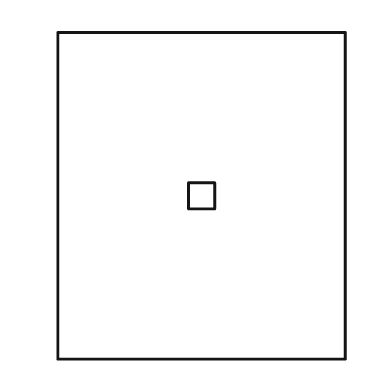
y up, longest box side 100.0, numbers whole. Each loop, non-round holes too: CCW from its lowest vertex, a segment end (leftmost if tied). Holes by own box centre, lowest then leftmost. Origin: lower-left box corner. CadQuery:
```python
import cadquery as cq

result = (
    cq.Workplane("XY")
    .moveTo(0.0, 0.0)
    .lineTo(88.0, 0.0)
    .lineTo(88.0, 100.0)
    .lineTo(0.0, 100.0)
    .close()
    .moveTo(40.0, 46.0)
    .lineTo(48.0, 46.0)
    .lineTo(48.0, 54.0)
    .lineTo(40.0, 54.0)
    .close()
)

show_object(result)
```